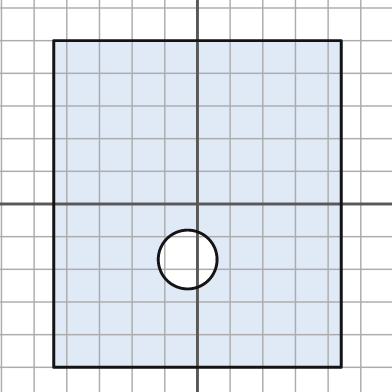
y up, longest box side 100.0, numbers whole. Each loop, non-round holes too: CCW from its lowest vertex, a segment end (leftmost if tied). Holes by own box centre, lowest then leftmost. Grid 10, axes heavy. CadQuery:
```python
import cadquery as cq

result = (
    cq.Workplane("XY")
    .moveTo(-44.0, -50.0)
    .lineTo(44.0, -50.0)
    .lineTo(44.0, 50.0)
    .lineTo(-44.0, 50.0)
    .close()
    .moveTo(-3.0, -17.0)
    .circle(9.0)
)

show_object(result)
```